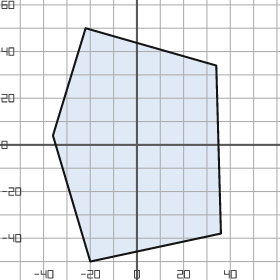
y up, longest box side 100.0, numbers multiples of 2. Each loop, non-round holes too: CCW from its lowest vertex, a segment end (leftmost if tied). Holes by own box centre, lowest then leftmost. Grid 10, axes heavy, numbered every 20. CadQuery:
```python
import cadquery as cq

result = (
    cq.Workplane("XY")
    .moveTo(-20.0, -50.0)
    .lineTo(36.0, -38.0)
    .lineTo(34.0, 34.0)
    .lineTo(-22.0, 50.0)
    .lineTo(-36.0, 4.0)
    .close()
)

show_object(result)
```